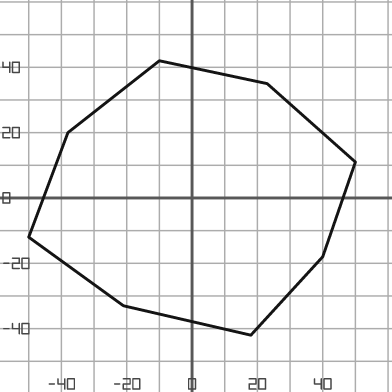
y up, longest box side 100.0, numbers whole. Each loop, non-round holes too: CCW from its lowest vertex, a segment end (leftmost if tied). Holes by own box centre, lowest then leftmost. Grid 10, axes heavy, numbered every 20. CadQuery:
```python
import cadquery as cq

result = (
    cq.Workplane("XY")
    .moveTo(18.0, -42.0)
    .lineTo(40.0, -18.0)
    .lineTo(50.0, 11.0)
    .lineTo(23.0, 35.0)
    .lineTo(-10.0, 42.0)
    .lineTo(-38.0, 20.0)
    .lineTo(-50.0, -12.0)
    .lineTo(-21.0, -33.0)
    .close()
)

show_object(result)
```